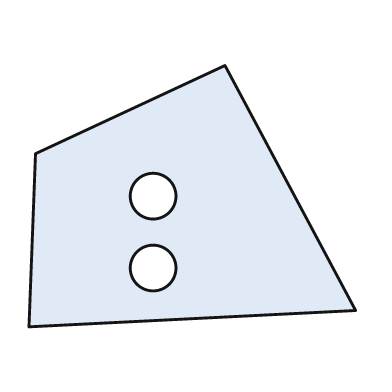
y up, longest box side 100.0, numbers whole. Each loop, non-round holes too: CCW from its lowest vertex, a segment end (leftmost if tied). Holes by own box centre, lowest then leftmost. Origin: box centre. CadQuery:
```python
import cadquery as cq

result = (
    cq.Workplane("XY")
    .moveTo(-50.0, -40.0)
    .lineTo(50.0, -35.0)
    .lineTo(10.0, 40.0)
    .lineTo(-48.0, 13.0)
    .close()
    .moveTo(-12.0, -22.0)
    .circle(7.0)
    .moveTo(-12.0, 0.0)
    .circle(7.0)
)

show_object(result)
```